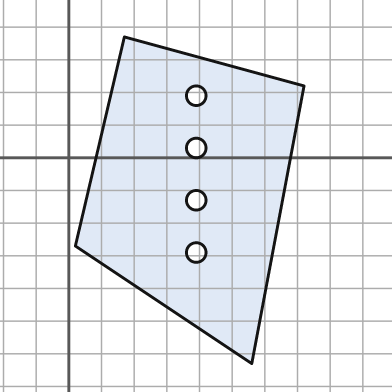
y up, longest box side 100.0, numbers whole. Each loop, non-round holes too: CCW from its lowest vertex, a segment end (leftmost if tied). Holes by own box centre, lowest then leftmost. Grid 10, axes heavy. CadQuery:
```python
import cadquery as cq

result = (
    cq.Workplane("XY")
    .moveTo(56.0, -63.0)
    .lineTo(72.0, 22.0)
    .lineTo(17.0, 37.0)
    .lineTo(2.0, -27.0)
    .close()
    .moveTo(39.0, -29.0)
    .circle(3.0)
    .moveTo(39.0, -13.0)
    .circle(3.0)
    .moveTo(39.0, 3.0)
    .circle(3.0)
    .moveTo(39.0, 19.0)
    .circle(3.0)
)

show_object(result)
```